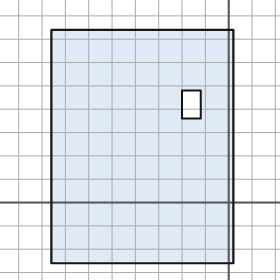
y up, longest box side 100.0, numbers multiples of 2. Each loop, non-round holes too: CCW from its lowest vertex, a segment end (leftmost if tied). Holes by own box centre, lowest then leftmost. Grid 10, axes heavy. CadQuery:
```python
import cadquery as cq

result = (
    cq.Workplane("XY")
    .moveTo(-76.0, -26.0)
    .lineTo(2.0, -26.0)
    .lineTo(2.0, 74.0)
    .lineTo(-76.0, 74.0)
    .close()
    .moveTo(-20.0, 36.0)
    .lineTo(-12.0, 36.0)
    .lineTo(-12.0, 48.0)
    .lineTo(-20.0, 48.0)
    .close()
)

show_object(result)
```